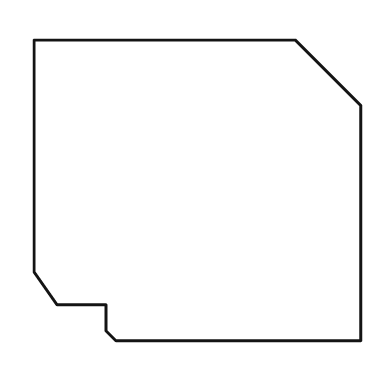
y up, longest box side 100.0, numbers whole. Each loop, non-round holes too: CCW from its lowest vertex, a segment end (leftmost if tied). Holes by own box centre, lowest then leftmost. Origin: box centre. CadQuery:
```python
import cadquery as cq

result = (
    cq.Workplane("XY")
    .moveTo(-25.0, -46.0)
    .lineTo(50.0, -46.0)
    .lineTo(50.0, 26.0)
    .lineTo(30.0, 46.0)
    .lineTo(-50.0, 46.0)
    .lineTo(-50.0, -25.0)
    .lineTo(-43.0, -35.0)
    .lineTo(-28.0, -35.0)
    .lineTo(-28.0, -43.0)
    .close()
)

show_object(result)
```